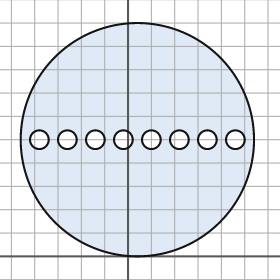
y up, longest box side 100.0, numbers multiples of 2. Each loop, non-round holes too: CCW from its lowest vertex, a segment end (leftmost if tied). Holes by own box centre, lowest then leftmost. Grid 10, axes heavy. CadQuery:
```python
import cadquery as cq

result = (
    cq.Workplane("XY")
    .moveTo(4.0, 50.0)
    .circle(50.0)
    .moveTo(-38.0, 50.0)
    .circle(4.0)
    .moveTo(-26.0, 50.0)
    .circle(4.0)
    .moveTo(-14.0, 50.0)
    .circle(4.0)
    .moveTo(-2.0, 50.0)
    .circle(4.0)
    .moveTo(10.0, 50.0)
    .circle(4.0)
    .moveTo(22.0, 50.0)
    .circle(4.0)
    .moveTo(34.0, 50.0)
    .circle(4.0)
    .moveTo(46.0, 50.0)
    .circle(4.0)
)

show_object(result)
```